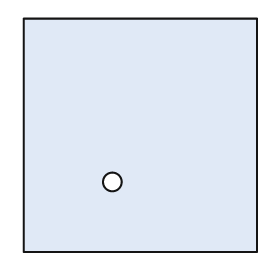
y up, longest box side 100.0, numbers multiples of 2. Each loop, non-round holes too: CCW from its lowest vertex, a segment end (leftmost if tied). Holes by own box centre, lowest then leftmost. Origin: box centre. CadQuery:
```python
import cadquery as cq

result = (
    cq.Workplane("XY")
    .moveTo(-50.0, -50.0)
    .lineTo(50.0, -50.0)
    .lineTo(50.0, 50.0)
    .lineTo(-50.0, 50.0)
    .close()
    .moveTo(-12.0, -20.0)
    .circle(4.0)
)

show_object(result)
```